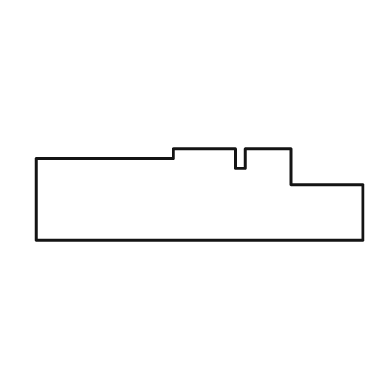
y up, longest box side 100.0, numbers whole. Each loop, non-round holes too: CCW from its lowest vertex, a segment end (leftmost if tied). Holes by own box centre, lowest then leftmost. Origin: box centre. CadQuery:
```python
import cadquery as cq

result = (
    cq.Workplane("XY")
    .moveTo(-50.0, -14.0)
    .lineTo(50.0, -14.0)
    .lineTo(50.0, 3.0)
    .lineTo(28.0, 3.0)
    .lineTo(28.0, 14.0)
    .lineTo(14.0, 14.0)
    .lineTo(14.0, 8.0)
    .lineTo(11.0, 8.0)
    .lineTo(11.0, 14.0)
    .lineTo(-8.0, 14.0)
    .lineTo(-8.0, 11.0)
    .lineTo(-50.0, 11.0)
    .close()
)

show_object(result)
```